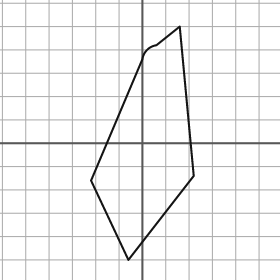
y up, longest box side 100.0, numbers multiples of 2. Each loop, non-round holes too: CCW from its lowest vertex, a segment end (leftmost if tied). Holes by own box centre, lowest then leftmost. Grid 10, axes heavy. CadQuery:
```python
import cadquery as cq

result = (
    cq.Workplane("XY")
    .moveTo(-6.0, -50.0)
    .lineTo(22.0, -14.0)
    .lineTo(16.0, 50.0)
    .lineTo(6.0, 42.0)
    .threePointArc((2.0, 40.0), (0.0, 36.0))
    .lineTo(-22.0, -16.0)
    .close()
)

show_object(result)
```